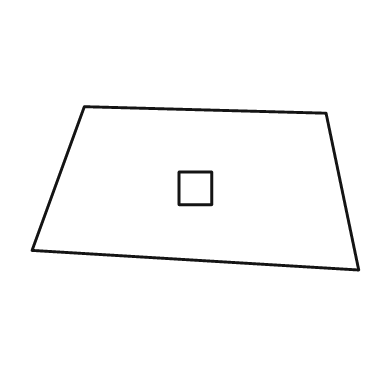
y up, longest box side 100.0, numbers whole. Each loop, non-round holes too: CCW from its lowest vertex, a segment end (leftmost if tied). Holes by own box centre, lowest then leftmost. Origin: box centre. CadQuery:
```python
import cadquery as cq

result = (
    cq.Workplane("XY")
    .moveTo(50.0, -25.0)
    .lineTo(40.0, 23.0)
    .lineTo(-34.0, 25.0)
    .lineTo(-50.0, -19.0)
    .close()
    .moveTo(-5.0, -5.0)
    .lineTo(5.0, -5.0)
    .lineTo(5.0, 5.0)
    .lineTo(-5.0, 5.0)
    .close()
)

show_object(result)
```